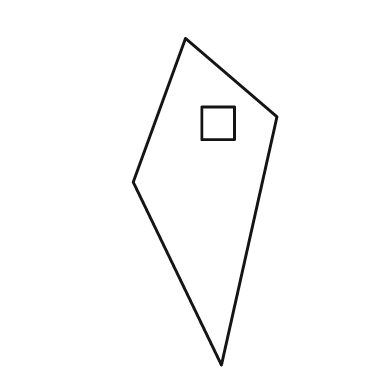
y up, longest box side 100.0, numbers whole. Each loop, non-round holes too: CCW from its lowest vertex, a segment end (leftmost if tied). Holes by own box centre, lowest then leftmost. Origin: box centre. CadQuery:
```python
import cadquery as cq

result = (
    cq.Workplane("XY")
    .moveTo(5.0, -50.0)
    .lineTo(22.0, 26.0)
    .lineTo(-6.0, 50.0)
    .lineTo(-22.0, 6.0)
    .close()
    .moveTo(-1.0, 19.0)
    .lineTo(9.0, 19.0)
    .lineTo(9.0, 29.0)
    .lineTo(-1.0, 29.0)
    .close()
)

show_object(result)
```